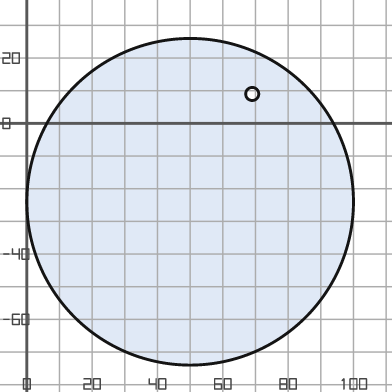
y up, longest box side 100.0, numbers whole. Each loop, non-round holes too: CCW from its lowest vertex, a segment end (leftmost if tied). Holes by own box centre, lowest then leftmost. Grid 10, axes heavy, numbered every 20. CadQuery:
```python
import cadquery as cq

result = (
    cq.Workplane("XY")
    .moveTo(50.0, -24.0)
    .circle(50.0)
    .moveTo(69.0, 9.0)
    .circle(2.0)
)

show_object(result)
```